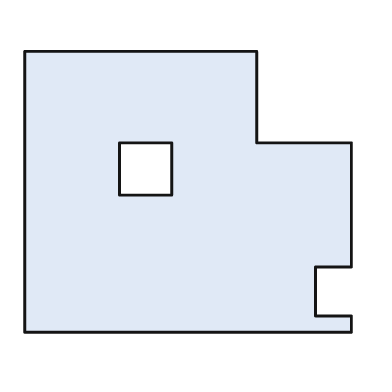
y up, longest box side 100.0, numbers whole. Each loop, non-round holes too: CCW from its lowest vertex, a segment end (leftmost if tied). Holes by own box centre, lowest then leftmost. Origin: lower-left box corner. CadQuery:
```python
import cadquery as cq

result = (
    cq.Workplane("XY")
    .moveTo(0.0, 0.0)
    .lineTo(100.0, 0.0)
    .lineTo(100.0, 5.0)
    .lineTo(89.0, 5.0)
    .lineTo(89.0, 20.0)
    .lineTo(100.0, 20.0)
    .lineTo(100.0, 58.0)
    .lineTo(71.0, 58.0)
    .lineTo(71.0, 86.0)
    .lineTo(0.0, 86.0)
    .close()
    .moveTo(29.0, 42.0)
    .lineTo(45.0, 42.0)
    .lineTo(45.0, 58.0)
    .lineTo(29.0, 58.0)
    .close()
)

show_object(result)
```